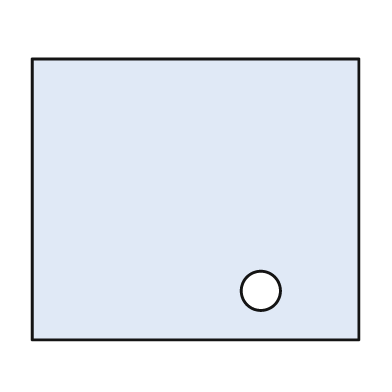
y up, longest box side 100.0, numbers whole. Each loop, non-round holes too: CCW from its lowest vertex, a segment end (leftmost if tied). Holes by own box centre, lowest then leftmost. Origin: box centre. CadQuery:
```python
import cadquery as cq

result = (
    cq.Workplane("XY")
    .moveTo(-50.0, -43.0)
    .lineTo(50.0, -43.0)
    .lineTo(50.0, 43.0)
    .lineTo(-50.0, 43.0)
    .close()
    .moveTo(20.0, -28.0)
    .circle(6.0)
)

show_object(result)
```